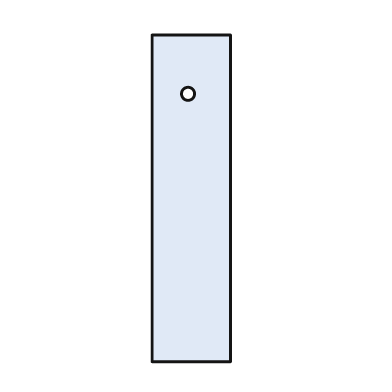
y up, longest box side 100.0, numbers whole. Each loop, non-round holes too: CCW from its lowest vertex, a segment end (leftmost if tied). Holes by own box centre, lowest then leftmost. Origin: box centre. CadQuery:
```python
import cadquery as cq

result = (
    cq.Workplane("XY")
    .moveTo(-12.0, -50.0)
    .lineTo(12.0, -50.0)
    .lineTo(12.0, 50.0)
    .lineTo(-12.0, 50.0)
    .close()
    .moveTo(-1.0, 32.0)
    .circle(2.0)
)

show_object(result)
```